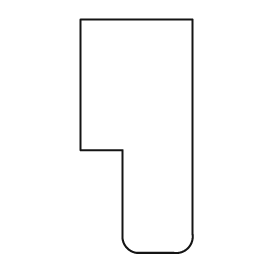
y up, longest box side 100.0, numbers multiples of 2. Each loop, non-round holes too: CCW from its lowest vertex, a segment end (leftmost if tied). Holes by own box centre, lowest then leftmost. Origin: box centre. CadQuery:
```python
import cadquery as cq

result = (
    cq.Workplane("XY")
    .moveTo(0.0, -50.0)
    .lineTo(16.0, -50.0)
    .threePointArc((22.0, -48.0), (24.0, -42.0))
    .lineTo(24.0, 50.0)
    .lineTo(-24.0, 50.0)
    .lineTo(-24.0, -6.0)
    .lineTo(-6.0, -6.0)
    .lineTo(-6.0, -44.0)
    .threePointArc((-4.0, -48.0), (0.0, -50.0))
    .close()
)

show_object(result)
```